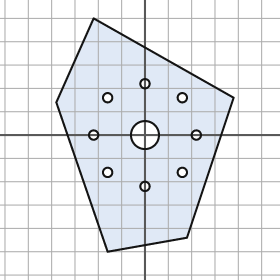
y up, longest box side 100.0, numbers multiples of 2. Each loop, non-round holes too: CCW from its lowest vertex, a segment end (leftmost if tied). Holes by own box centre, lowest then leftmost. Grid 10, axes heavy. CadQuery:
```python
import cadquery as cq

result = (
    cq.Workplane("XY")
    .moveTo(-16.0, -50.0)
    .lineTo(18.0, -44.0)
    .lineTo(38.0, 16.0)
    .lineTo(-22.0, 50.0)
    .lineTo(-38.0, 14.0)
    .close()
    .moveTo(0.0, -22.0)
    .circle(2.0)
    .moveTo(-16.0, -16.0)
    .circle(2.0)
    .moveTo(16.0, -16.0)
    .circle(2.0)
    .moveTo(-22.0, 0.0)
    .circle(2.0)
    .moveTo(0.0, 0.0)
    .circle(6.0)
    .moveTo(22.0, 0.0)
    .circle(2.0)
    .moveTo(-16.0, 16.0)
    .circle(2.0)
    .moveTo(16.0, 16.0)
    .circle(2.0)
    .moveTo(0.0, 22.0)
    .circle(2.0)
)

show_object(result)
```